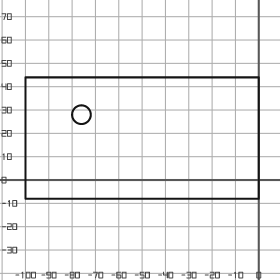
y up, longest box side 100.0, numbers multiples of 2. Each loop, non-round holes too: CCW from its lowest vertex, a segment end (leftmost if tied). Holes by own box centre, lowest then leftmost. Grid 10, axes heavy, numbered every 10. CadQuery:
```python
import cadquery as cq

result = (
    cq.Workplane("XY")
    .moveTo(-100.0, -8.0)
    .lineTo(0.0, -8.0)
    .lineTo(0.0, 44.0)
    .lineTo(-100.0, 44.0)
    .close()
    .moveTo(-76.0, 28.0)
    .circle(4.0)
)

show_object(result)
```